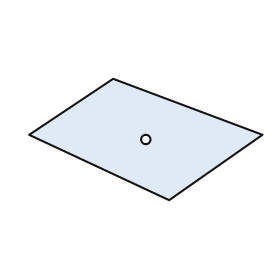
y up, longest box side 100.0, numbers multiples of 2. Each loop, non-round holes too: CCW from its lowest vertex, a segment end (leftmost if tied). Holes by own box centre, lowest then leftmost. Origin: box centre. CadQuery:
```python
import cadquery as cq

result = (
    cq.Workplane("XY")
    .moveTo(10.0, -26.0)
    .lineTo(50.0, 2.0)
    .lineTo(-14.0, 26.0)
    .lineTo(-50.0, 2.0)
    .close()
    .moveTo(0.0, 0.0)
    .circle(2.0)
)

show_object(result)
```